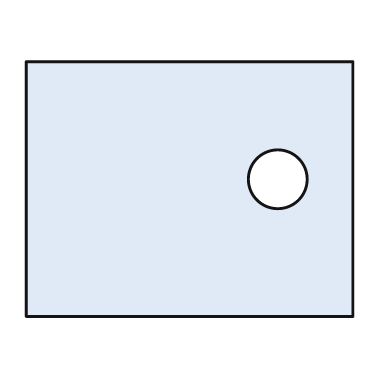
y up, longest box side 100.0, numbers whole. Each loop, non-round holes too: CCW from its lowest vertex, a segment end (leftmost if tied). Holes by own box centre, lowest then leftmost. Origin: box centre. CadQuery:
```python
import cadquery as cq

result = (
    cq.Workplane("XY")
    .moveTo(-50.0, -39.0)
    .lineTo(50.0, -39.0)
    .lineTo(50.0, 39.0)
    .lineTo(-50.0, 39.0)
    .close()
    .moveTo(27.0, 3.0)
    .circle(9.0)
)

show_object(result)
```